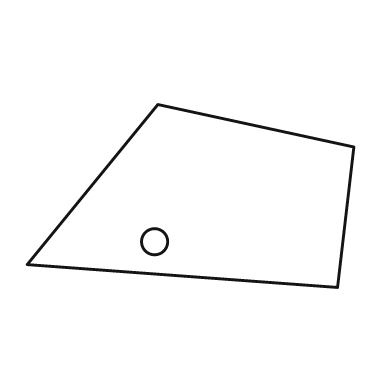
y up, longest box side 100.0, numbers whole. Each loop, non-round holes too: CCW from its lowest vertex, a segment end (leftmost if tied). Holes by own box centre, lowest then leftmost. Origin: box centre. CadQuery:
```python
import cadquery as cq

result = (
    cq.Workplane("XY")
    .moveTo(45.0, -28.0)
    .lineTo(50.0, 15.0)
    .lineTo(-10.0, 28.0)
    .lineTo(-50.0, -21.0)
    .close()
    .moveTo(-11.0, -14.0)
    .circle(4.0)
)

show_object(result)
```